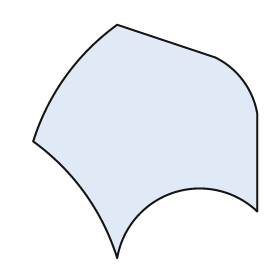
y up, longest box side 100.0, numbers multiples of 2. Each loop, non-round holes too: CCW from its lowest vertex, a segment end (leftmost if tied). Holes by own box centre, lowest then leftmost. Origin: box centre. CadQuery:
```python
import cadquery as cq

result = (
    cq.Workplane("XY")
    .moveTo(-12.0, -50.0)
    .threePointArc((12.0, -22.0), (48.0, -30.0))
    .lineTo(48.0, 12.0)
    .threePointArc((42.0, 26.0), (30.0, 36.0))
    .lineTo(-12.0, 50.0)
    .threePointArc((-34.0, 28.0), (-48.0, 0.0))
    .threePointArc((-26.0, -22.0), (-12.0, -50.0))
    .close()
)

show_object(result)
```